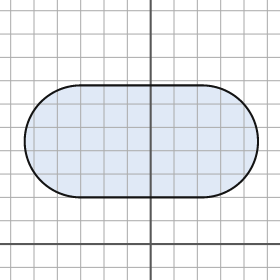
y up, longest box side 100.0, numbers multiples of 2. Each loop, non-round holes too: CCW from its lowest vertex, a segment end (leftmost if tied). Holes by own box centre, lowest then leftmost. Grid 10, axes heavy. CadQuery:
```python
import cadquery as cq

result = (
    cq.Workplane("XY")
    .moveTo(-30.0, 20.0)
    .lineTo(22.0, 20.0)
    .threePointArc((46.0, 44.0), (22.0, 68.0))
    .lineTo(-30.0, 68.0)
    .threePointArc((-54.0, 44.0), (-30.0, 20.0))
    .close()
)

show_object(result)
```